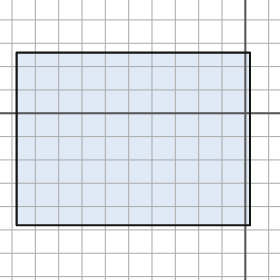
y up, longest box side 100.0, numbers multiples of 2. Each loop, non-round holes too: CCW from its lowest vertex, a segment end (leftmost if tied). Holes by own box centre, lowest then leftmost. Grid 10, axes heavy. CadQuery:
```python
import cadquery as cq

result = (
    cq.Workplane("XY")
    .moveTo(-98.0, -48.0)
    .lineTo(2.0, -48.0)
    .lineTo(2.0, 26.0)
    .lineTo(-98.0, 26.0)
    .close()
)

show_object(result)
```